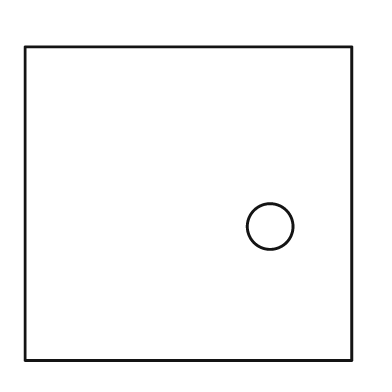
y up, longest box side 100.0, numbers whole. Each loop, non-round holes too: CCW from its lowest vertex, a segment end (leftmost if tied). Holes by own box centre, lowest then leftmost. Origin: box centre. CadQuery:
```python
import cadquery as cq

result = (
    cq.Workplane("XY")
    .moveTo(-50.0, -48.0)
    .lineTo(50.0, -48.0)
    .lineTo(50.0, 48.0)
    .lineTo(-50.0, 48.0)
    .close()
    .moveTo(25.0, -7.0)
    .circle(7.0)
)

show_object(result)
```